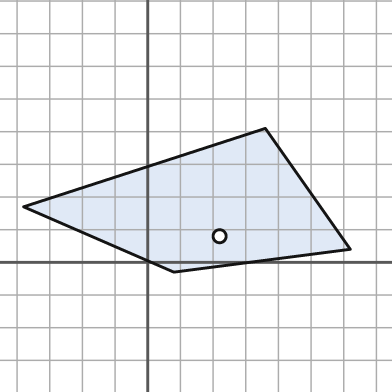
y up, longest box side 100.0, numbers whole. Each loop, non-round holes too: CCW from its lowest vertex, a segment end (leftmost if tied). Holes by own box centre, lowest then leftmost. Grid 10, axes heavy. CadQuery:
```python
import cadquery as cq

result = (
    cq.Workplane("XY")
    .moveTo(8.0, -3.0)
    .lineTo(62.0, 4.0)
    .lineTo(36.0, 41.0)
    .lineTo(-38.0, 17.0)
    .close()
    .moveTo(22.0, 8.0)
    .circle(2.0)
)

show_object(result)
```